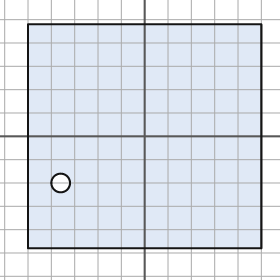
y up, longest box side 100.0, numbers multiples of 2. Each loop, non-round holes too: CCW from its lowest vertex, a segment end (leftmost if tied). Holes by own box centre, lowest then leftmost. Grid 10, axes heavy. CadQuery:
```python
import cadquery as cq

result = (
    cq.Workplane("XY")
    .moveTo(-50.0, -48.0)
    .lineTo(50.0, -48.0)
    .lineTo(50.0, 48.0)
    .lineTo(-50.0, 48.0)
    .close()
    .moveTo(-36.0, -20.0)
    .circle(4.0)
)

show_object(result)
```